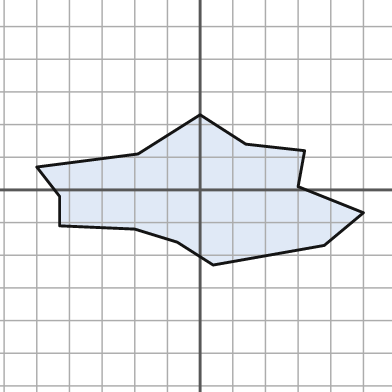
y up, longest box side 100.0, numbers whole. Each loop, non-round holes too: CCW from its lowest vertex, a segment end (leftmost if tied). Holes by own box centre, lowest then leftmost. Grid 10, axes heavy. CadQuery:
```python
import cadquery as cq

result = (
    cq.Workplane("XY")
    .moveTo(4.0, -23.0)
    .lineTo(38.0, -17.0)
    .lineTo(50.0, -7.0)
    .lineTo(30.0, 1.0)
    .lineTo(32.0, 12.0)
    .lineTo(14.0, 14.0)
    .lineTo(0.0, 23.0)
    .lineTo(-19.0, 11.0)
    .lineTo(-50.0, 7.0)
    .lineTo(-43.0, -2.0)
    .lineTo(-43.0, -11.0)
    .lineTo(-20.0, -12.0)
    .lineTo(-7.0, -16.0)
    .close()
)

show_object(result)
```